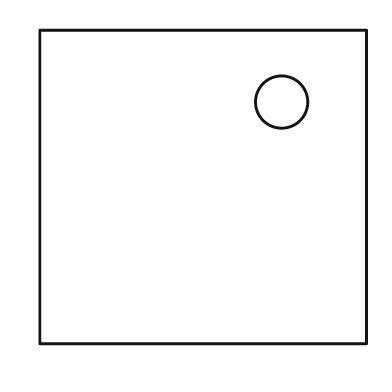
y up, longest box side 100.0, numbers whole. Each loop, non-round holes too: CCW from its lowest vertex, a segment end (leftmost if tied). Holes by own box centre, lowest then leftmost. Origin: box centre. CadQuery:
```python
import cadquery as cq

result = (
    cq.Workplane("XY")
    .moveTo(-50.0, -48.0)
    .lineTo(50.0, -48.0)
    .lineTo(50.0, 48.0)
    .lineTo(-50.0, 48.0)
    .close()
    .moveTo(24.0, 26.0)
    .circle(8.0)
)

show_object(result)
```